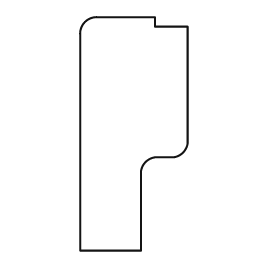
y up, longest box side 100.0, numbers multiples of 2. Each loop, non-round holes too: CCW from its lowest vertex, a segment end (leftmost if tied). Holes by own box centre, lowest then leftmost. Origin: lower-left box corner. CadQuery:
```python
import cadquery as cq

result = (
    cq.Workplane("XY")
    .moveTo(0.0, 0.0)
    .lineTo(26.0, 0.0)
    .lineTo(26.0, 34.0)
    .threePointArc((28.0, 38.0), (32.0, 40.0))
    .lineTo(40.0, 40.0)
    .threePointArc((44.0, 42.0), (46.0, 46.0))
    .lineTo(46.0, 96.0)
    .lineTo(32.0, 96.0)
    .lineTo(32.0, 100.0)
    .lineTo(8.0, 100.0)
    .threePointArc((2.0, 98.0), (0.0, 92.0))
    .close()
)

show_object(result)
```